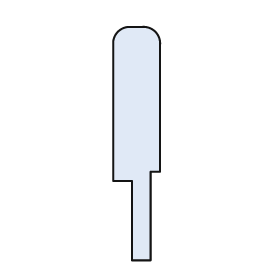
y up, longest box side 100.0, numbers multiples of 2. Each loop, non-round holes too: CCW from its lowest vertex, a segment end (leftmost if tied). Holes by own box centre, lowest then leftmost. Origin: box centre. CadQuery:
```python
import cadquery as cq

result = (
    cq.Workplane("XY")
    .moveTo(-2.0, -50.0)
    .lineTo(6.0, -50.0)
    .lineTo(6.0, -12.0)
    .lineTo(10.0, -12.0)
    .lineTo(10.0, 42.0)
    .threePointArc((8.0, 48.0), (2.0, 50.0))
    .lineTo(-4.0, 50.0)
    .threePointArc((-8.0, 48.0), (-10.0, 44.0))
    .lineTo(-10.0, -16.0)
    .lineTo(-2.0, -16.0)
    .close()
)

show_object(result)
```